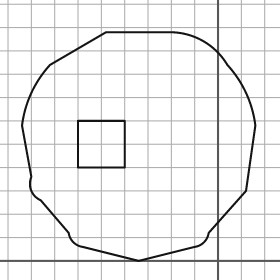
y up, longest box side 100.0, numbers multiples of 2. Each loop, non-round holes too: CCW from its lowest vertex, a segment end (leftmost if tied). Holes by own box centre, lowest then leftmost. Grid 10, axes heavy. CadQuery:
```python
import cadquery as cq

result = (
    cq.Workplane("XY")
    .moveTo(-34.0, 0.0)
    .lineTo(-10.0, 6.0)
    .threePointArc((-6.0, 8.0), (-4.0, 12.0))
    .lineTo(12.0, 30.0)
    .lineTo(16.0, 58.0)
    .threePointArc((12.0, 72.0), (4.0, 84.0))
    .threePointArc((-6.0, 94.0), (-20.0, 98.0))
    .lineTo(-48.0, 98.0)
    .lineTo(-72.0, 84.0)
    .threePointArc((-80.0, 72.0), (-84.0, 58.0))
    .lineTo(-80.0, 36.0)
    .threePointArc((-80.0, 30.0), (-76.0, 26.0))
    .lineTo(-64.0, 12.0)
    .threePointArc((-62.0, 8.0), (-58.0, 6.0))
    .close()
    .moveTo(-60.0, 40.0)
    .lineTo(-40.0, 40.0)
    .lineTo(-40.0, 60.0)
    .lineTo(-60.0, 60.0)
    .close()
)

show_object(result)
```